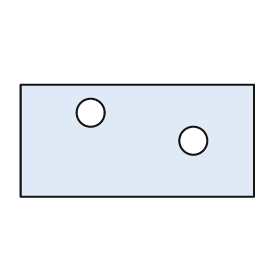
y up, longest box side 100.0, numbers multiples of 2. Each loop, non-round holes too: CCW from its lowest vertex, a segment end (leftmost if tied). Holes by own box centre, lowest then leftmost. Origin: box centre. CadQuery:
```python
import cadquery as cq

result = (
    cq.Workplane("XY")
    .moveTo(-50.0, -24.0)
    .lineTo(50.0, -24.0)
    .lineTo(50.0, 24.0)
    .lineTo(-50.0, 24.0)
    .close()
    .moveTo(24.0, 0.0)
    .circle(6.0)
    .moveTo(-20.0, 12.0)
    .circle(6.0)
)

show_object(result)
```